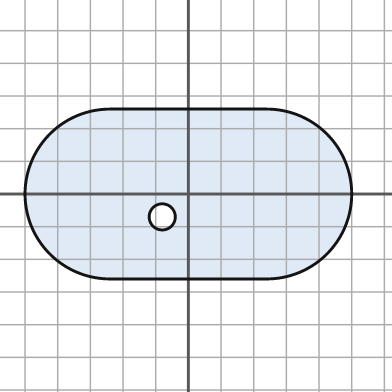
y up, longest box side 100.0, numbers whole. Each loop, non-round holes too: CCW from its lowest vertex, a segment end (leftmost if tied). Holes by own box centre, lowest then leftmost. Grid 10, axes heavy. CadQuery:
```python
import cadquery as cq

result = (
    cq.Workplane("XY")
    .moveTo(-24.0, -26.0)
    .lineTo(24.0, -26.0)
    .threePointArc((50.0, 0.0), (24.0, 26.0))
    .lineTo(-24.0, 26.0)
    .threePointArc((-50.0, 0.0), (-24.0, -26.0))
    .close()
    .moveTo(-8.0, -7.0)
    .circle(4.0)
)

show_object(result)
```